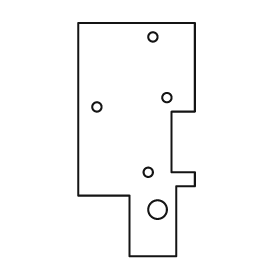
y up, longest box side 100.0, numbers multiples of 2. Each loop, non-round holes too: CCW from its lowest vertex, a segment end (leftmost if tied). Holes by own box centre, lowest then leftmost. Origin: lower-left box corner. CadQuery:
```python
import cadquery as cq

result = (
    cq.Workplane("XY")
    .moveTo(22.0, 0.0)
    .lineTo(42.0, 0.0)
    .lineTo(42.0, 30.0)
    .lineTo(50.0, 30.0)
    .lineTo(50.0, 36.0)
    .lineTo(40.0, 36.0)
    .lineTo(40.0, 62.0)
    .lineTo(50.0, 62.0)
    .lineTo(50.0, 100.0)
    .lineTo(0.0, 100.0)
    .lineTo(0.0, 26.0)
    .lineTo(22.0, 26.0)
    .close()
    .moveTo(34.0, 20.0)
    .circle(4.0)
    .moveTo(30.0, 36.0)
    .circle(2.0)
    .moveTo(8.0, 64.0)
    .circle(2.0)
    .moveTo(38.0, 68.0)
    .circle(2.0)
    .moveTo(32.0, 94.0)
    .circle(2.0)
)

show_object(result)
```